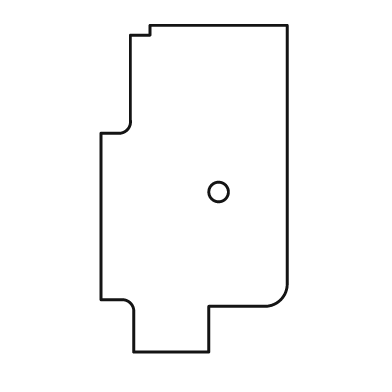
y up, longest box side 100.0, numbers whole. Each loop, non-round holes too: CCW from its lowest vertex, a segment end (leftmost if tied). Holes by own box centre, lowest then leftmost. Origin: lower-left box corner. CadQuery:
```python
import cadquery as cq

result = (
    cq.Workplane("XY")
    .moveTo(10.0, 0.0)
    .lineTo(33.0, 0.0)
    .lineTo(33.0, 14.0)
    .lineTo(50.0, 14.0)
    .threePointArc((55.0, 16.0), (57.0, 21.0))
    .lineTo(57.0, 100.0)
    .lineTo(15.0, 100.0)
    .lineTo(15.0, 97.0)
    .lineTo(9.0, 97.0)
    .lineTo(9.0, 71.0)
    .threePointArc((8.0, 68.0), (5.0, 67.0))
    .lineTo(0.0, 67.0)
    .lineTo(0.0, 16.0)
    .lineTo(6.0, 16.0)
    .threePointArc((9.0, 15.0), (10.0, 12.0))
    .close()
    .moveTo(36.0, 49.0)
    .circle(3.0)
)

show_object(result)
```